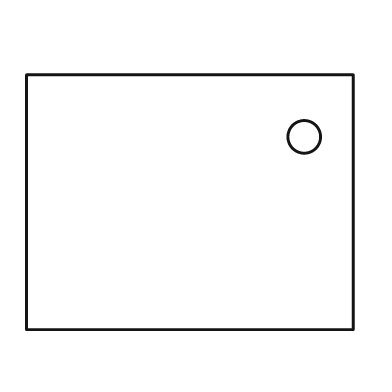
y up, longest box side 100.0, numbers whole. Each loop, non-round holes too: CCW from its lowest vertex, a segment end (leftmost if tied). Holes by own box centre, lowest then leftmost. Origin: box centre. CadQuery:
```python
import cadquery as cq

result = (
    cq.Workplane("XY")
    .moveTo(-50.0, -39.0)
    .lineTo(50.0, -39.0)
    .lineTo(50.0, 39.0)
    .lineTo(-50.0, 39.0)
    .close()
    .moveTo(35.0, 20.0)
    .circle(5.0)
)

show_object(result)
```